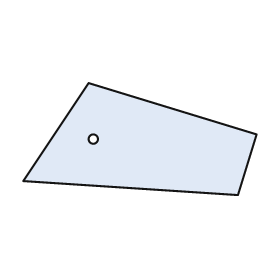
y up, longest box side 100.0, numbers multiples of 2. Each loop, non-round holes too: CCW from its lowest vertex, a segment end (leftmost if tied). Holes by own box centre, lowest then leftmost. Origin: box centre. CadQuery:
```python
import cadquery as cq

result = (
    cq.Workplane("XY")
    .moveTo(42.0, -24.0)
    .lineTo(50.0, 2.0)
    .lineTo(-22.0, 24.0)
    .lineTo(-50.0, -18.0)
    .close()
    .moveTo(-20.0, 0.0)
    .circle(2.0)
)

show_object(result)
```